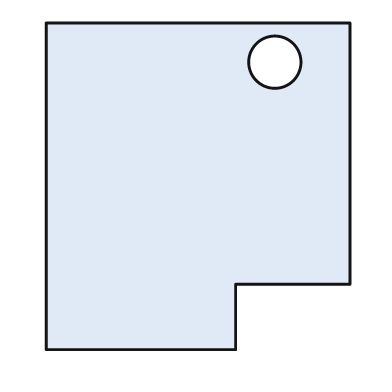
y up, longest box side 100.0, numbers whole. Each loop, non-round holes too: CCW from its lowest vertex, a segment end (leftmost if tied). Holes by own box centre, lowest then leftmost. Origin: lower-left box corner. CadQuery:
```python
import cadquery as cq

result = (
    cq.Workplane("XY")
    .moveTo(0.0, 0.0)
    .lineTo(58.0, 0.0)
    .lineTo(58.0, 20.0)
    .lineTo(93.0, 20.0)
    .lineTo(93.0, 100.0)
    .lineTo(0.0, 100.0)
    .close()
    .moveTo(70.0, 88.0)
    .circle(8.0)
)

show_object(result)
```